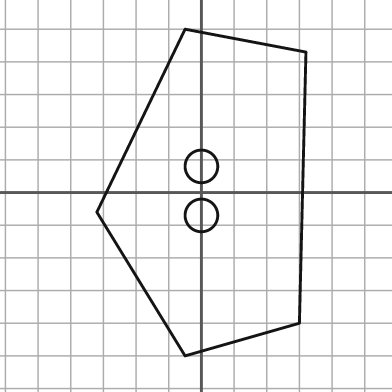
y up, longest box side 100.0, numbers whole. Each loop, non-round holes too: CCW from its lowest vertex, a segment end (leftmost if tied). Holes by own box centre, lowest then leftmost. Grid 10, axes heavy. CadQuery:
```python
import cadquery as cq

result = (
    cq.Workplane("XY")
    .moveTo(-5.0, -50.0)
    .lineTo(30.0, -40.0)
    .lineTo(32.0, 43.0)
    .lineTo(-5.0, 50.0)
    .lineTo(-32.0, -6.0)
    .close()
    .moveTo(0.0, -7.0)
    .circle(5.0)
    .moveTo(0.0, 8.0)
    .circle(5.0)
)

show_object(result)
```